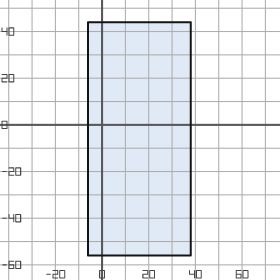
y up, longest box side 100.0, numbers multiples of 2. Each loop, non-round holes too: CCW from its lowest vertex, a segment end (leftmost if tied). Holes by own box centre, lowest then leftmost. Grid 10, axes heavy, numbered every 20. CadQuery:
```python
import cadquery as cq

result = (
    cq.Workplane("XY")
    .moveTo(-6.0, -56.0)
    .lineTo(38.0, -56.0)
    .lineTo(38.0, 44.0)
    .lineTo(-6.0, 44.0)
    .close()
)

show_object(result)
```